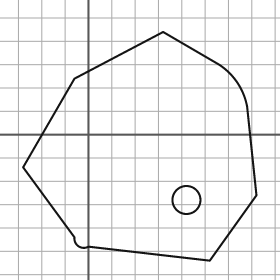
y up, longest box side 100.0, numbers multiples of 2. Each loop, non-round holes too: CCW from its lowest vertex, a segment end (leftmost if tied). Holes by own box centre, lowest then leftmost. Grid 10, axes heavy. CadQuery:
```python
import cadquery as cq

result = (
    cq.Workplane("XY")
    .moveTo(52.0, -54.0)
    .lineTo(72.0, -26.0)
    .lineTo(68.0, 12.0)
    .threePointArc((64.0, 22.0), (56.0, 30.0))
    .lineTo(32.0, 44.0)
    .lineTo(-6.0, 24.0)
    .lineTo(-28.0, -14.0)
    .lineTo(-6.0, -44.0)
    .threePointArc((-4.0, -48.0), (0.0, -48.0))
    .close()
    .moveTo(42.0, -28.0)
    .circle(6.0)
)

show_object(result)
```